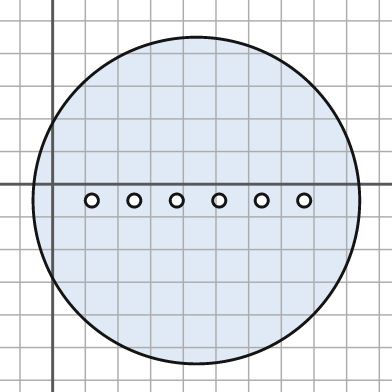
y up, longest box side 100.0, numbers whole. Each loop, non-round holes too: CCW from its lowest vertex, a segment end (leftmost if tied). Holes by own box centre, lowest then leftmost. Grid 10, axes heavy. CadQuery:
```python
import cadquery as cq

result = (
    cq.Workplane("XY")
    .moveTo(44.0, -5.0)
    .circle(50.0)
    .moveTo(12.0, -5.0)
    .circle(2.0)
    .moveTo(25.0, -5.0)
    .circle(2.0)
    .moveTo(38.0, -5.0)
    .circle(2.0)
    .moveTo(51.0, -5.0)
    .circle(2.0)
    .moveTo(64.0, -5.0)
    .circle(2.0)
    .moveTo(77.0, -5.0)
    .circle(2.0)
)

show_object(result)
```